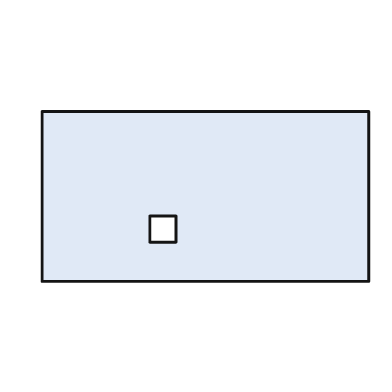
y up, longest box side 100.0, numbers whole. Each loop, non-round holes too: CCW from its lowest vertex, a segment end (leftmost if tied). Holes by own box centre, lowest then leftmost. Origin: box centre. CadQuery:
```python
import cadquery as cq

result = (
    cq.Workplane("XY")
    .moveTo(-50.0, -26.0)
    .lineTo(50.0, -26.0)
    .lineTo(50.0, 26.0)
    .lineTo(-50.0, 26.0)
    .close()
    .moveTo(-17.0, -14.0)
    .lineTo(-9.0, -14.0)
    .lineTo(-9.0, -6.0)
    .lineTo(-17.0, -6.0)
    .close()
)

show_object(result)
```